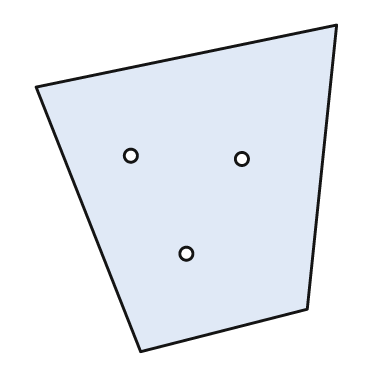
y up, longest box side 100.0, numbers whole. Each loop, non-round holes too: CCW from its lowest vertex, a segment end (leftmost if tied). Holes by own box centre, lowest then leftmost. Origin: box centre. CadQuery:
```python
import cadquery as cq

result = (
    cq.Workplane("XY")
    .moveTo(-14.0, -50.0)
    .lineTo(37.0, -37.0)
    .lineTo(46.0, 50.0)
    .lineTo(-46.0, 31.0)
    .close()
    .moveTo(0.0, -20.0)
    .circle(2.0)
    .moveTo(17.0, 9.0)
    .circle(2.0)
    .moveTo(-17.0, 10.0)
    .circle(2.0)
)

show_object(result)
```